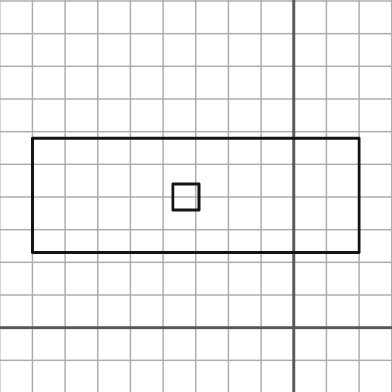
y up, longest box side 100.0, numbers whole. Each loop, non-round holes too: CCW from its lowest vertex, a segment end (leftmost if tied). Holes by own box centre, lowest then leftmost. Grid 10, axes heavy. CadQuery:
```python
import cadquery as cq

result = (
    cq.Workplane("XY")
    .moveTo(-80.0, 23.0)
    .lineTo(20.0, 23.0)
    .lineTo(20.0, 58.0)
    .lineTo(-80.0, 58.0)
    .close()
    .moveTo(-37.0, 36.0)
    .lineTo(-29.0, 36.0)
    .lineTo(-29.0, 44.0)
    .lineTo(-37.0, 44.0)
    .close()
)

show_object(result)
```